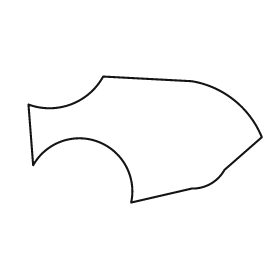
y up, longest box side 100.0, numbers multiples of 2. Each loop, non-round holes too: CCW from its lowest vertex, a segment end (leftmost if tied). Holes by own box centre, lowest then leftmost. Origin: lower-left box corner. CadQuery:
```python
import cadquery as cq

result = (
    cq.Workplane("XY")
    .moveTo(44.0, 0.0)
    .lineTo(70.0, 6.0)
    .threePointArc((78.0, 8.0), (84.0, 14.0))
    .lineTo(100.0, 28.0)
    .threePointArc((88.0, 44.0), (70.0, 52.0))
    .lineTo(32.0, 54.0)
    .threePointArc((18.0, 42.0), (0.0, 42.0))
    .lineTo(2.0, 16.0)
    .threePointArc((30.0, 26.0), (44.0, 0.0))
    .close()
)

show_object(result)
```